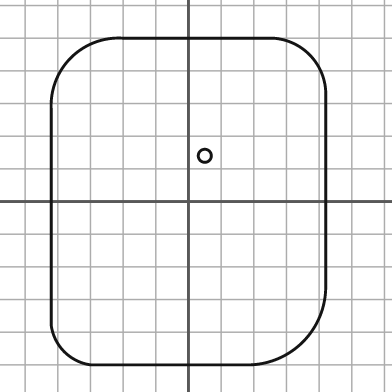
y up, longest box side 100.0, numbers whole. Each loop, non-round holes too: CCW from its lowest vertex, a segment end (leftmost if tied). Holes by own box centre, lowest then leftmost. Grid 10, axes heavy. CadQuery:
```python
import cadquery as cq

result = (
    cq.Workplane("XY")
    .moveTo(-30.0, -50.0)
    .lineTo(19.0, -50.0)
    .threePointArc((35.0, -43.0), (42.0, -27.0))
    .lineTo(42.0, 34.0)
    .threePointArc((37.0, 45.0), (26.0, 50.0))
    .lineTo(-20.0, 50.0)
    .threePointArc((-36.0, 44.0), (-42.0, 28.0))
    .lineTo(-42.0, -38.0)
    .threePointArc((-38.0, -46.0), (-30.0, -50.0))
    .close()
    .moveTo(5.0, 14.0)
    .circle(2.0)
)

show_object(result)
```